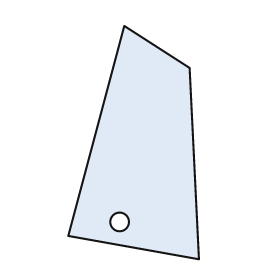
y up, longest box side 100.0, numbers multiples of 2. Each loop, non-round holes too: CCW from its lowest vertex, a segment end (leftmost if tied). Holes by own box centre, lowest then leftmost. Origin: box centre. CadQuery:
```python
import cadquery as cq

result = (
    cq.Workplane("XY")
    .moveTo(28.0, -50.0)
    .lineTo(24.0, 32.0)
    .lineTo(-4.0, 50.0)
    .lineTo(-28.0, -40.0)
    .close()
    .moveTo(-6.0, -34.0)
    .circle(4.0)
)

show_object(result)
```